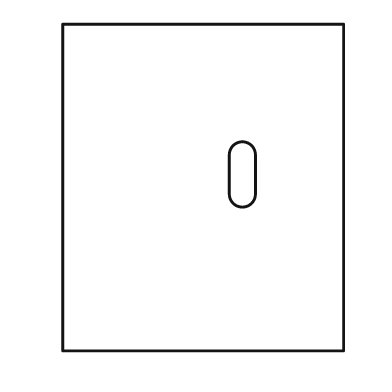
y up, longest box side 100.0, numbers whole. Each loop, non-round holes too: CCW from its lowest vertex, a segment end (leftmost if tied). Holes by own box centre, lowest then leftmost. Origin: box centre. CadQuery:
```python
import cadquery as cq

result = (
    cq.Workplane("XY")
    .moveTo(-43.0, -50.0)
    .lineTo(43.0, -50.0)
    .lineTo(43.0, 50.0)
    .lineTo(-43.0, 50.0)
    .close()
    .moveTo(8.0, -2.0)
    .threePointArc((12.0, -6.0), (16.0, -2.0))
    .lineTo(16.0, 10.0)
    .threePointArc((12.0, 14.0), (8.0, 10.0))
    .close()
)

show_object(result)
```